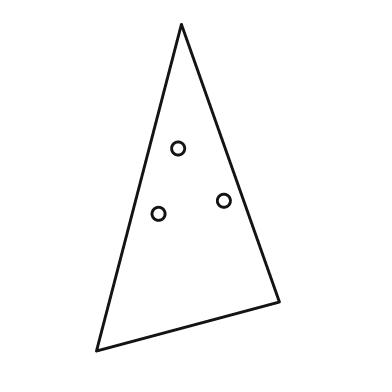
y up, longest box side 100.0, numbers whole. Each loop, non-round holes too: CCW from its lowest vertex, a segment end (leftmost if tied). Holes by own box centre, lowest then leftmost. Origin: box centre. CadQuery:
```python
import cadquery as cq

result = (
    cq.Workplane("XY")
    .moveTo(-28.0, -50.0)
    .lineTo(28.0, -35.0)
    .lineTo(-2.0, 50.0)
    .close()
    .moveTo(-9.0, -8.0)
    .circle(2.0)
    .moveTo(11.0, -4.0)
    .circle(2.0)
    .moveTo(-3.0, 12.0)
    .circle(2.0)
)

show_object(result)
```